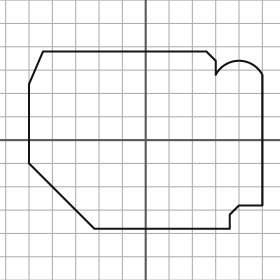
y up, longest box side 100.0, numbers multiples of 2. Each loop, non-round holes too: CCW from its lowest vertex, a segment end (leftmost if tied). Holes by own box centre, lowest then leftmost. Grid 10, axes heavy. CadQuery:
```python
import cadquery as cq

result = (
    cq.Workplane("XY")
    .moveTo(-22.0, -38.0)
    .lineTo(36.0, -38.0)
    .lineTo(36.0, -32.0)
    .lineTo(40.0, -28.0)
    .lineTo(50.0, -28.0)
    .lineTo(50.0, 28.0)
    .threePointArc((40.0, 34.0), (30.0, 28.0))
    .lineTo(30.0, 34.0)
    .lineTo(26.0, 38.0)
    .lineTo(-44.0, 38.0)
    .lineTo(-50.0, 24.0)
    .lineTo(-50.0, -10.0)
    .close()
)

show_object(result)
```